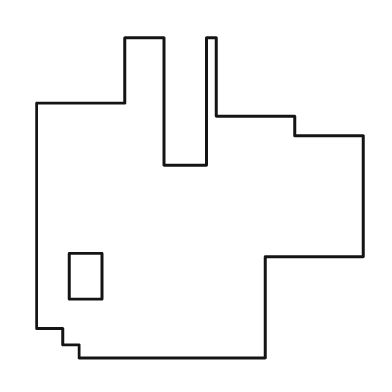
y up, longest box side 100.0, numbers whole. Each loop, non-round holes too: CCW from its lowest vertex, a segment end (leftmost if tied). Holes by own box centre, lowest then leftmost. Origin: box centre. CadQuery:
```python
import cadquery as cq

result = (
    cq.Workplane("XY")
    .moveTo(-37.0, -49.0)
    .lineTo(20.0, -49.0)
    .lineTo(20.0, -18.0)
    .lineTo(50.0, -18.0)
    .lineTo(50.0, 19.0)
    .lineTo(29.0, 19.0)
    .lineTo(29.0, 25.0)
    .lineTo(5.0, 25.0)
    .lineTo(5.0, 49.0)
    .lineTo(2.0, 49.0)
    .lineTo(2.0, 10.0)
    .lineTo(-11.0, 10.0)
    .lineTo(-11.0, 49.0)
    .lineTo(-23.0, 49.0)
    .lineTo(-23.0, 29.0)
    .lineTo(-50.0, 29.0)
    .lineTo(-50.0, -40.0)
    .lineTo(-42.0, -40.0)
    .lineTo(-42.0, -45.0)
    .lineTo(-37.0, -45.0)
    .close()
    .moveTo(-40.0, -31.0)
    .lineTo(-30.0, -31.0)
    .lineTo(-30.0, -17.0)
    .lineTo(-40.0, -17.0)
    .close()
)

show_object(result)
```